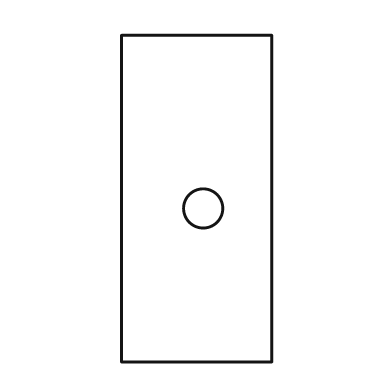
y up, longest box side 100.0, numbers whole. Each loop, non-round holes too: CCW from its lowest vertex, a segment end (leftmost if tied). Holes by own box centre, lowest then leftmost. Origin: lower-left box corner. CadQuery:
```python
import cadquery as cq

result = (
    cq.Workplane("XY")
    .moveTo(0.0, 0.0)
    .lineTo(46.0, 0.0)
    .lineTo(46.0, 100.0)
    .lineTo(0.0, 100.0)
    .close()
    .moveTo(25.0, 47.0)
    .circle(6.0)
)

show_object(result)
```